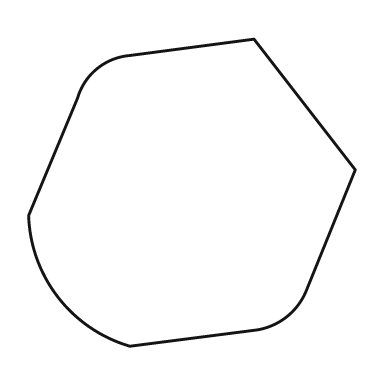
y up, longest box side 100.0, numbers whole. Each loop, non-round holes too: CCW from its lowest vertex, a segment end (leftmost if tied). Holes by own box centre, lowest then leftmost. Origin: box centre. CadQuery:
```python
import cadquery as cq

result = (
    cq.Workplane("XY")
    .moveTo(-19.0, -47.0)
    .lineTo(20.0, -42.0)
    .threePointArc((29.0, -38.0), (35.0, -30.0))
    .lineTo(50.0, 7.0)
    .lineTo(19.0, 47.0)
    .lineTo(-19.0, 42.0)
    .threePointArc((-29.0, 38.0), (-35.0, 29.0))
    .lineTo(-50.0, -7.0)
    .threePointArc((-41.0, -32.0), (-19.0, -47.0))
    .close()
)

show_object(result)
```